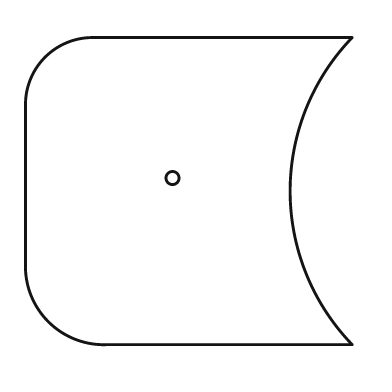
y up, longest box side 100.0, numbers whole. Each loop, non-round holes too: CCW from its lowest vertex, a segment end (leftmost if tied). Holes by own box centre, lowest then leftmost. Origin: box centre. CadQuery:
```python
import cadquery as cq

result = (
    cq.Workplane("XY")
    .moveTo(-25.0, -47.0)
    .lineTo(50.0, -47.0)
    .threePointArc((31.0, 0.0), (50.0, 47.0))
    .lineTo(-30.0, 47.0)
    .threePointArc((-44.0, 41.0), (-50.0, 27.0))
    .lineTo(-50.0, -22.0)
    .threePointArc((-43.0, -40.0), (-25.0, -47.0))
    .close()
    .moveTo(-5.0, 4.0)
    .circle(2.0)
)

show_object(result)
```